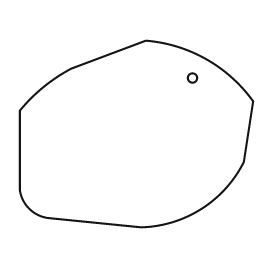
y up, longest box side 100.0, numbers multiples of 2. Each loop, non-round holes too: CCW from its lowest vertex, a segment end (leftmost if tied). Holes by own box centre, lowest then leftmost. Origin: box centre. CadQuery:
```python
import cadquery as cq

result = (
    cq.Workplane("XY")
    .moveTo(2.0, -40.0)
    .threePointArc((28.0, -32.0), (46.0, -12.0))
    .lineTo(50.0, 14.0)
    .threePointArc((30.0, 32.0), (4.0, 40.0))
    .lineTo(-28.0, 28.0)
    .threePointArc((-40.0, 20.0), (-50.0, 10.0))
    .lineTo(-50.0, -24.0)
    .threePointArc((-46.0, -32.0), (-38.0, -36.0))
    .close()
    .moveTo(24.0, 24.0)
    .circle(2.0)
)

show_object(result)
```